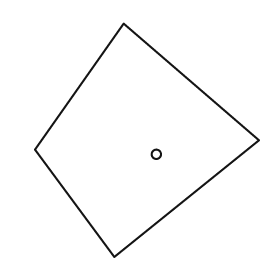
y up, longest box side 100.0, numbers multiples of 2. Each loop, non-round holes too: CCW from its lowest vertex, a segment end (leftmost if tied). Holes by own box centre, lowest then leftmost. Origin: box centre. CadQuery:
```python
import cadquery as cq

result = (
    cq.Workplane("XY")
    .moveTo(-14.0, -50.0)
    .lineTo(48.0, 0.0)
    .lineTo(-10.0, 50.0)
    .lineTo(-48.0, -4.0)
    .close()
    .moveTo(4.0, -6.0)
    .circle(2.0)
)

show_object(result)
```